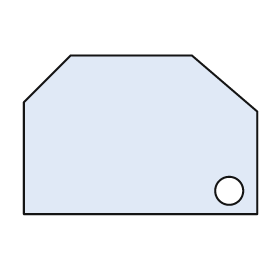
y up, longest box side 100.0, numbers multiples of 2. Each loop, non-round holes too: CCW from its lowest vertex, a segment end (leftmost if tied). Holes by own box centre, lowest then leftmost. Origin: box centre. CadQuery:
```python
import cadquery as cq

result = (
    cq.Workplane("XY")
    .moveTo(-50.0, -34.0)
    .lineTo(50.0, -34.0)
    .lineTo(50.0, 10.0)
    .lineTo(22.0, 34.0)
    .lineTo(-30.0, 34.0)
    .lineTo(-50.0, 14.0)
    .close()
    .moveTo(38.0, -24.0)
    .circle(6.0)
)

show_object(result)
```